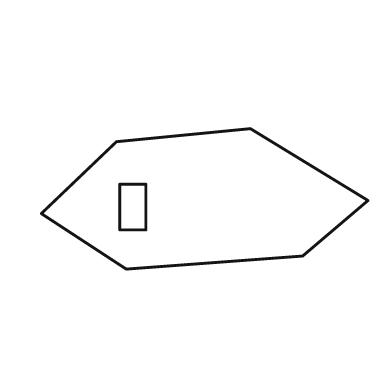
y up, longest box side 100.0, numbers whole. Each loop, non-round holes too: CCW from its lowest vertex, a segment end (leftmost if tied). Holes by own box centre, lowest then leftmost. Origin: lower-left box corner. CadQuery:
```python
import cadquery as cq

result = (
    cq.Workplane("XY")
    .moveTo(26.0, 0.0)
    .lineTo(80.0, 4.0)
    .lineTo(100.0, 21.0)
    .lineTo(64.0, 43.0)
    .lineTo(23.0, 39.0)
    .lineTo(0.0, 17.0)
    .close()
    .moveTo(24.0, 12.0)
    .lineTo(32.0, 12.0)
    .lineTo(32.0, 26.0)
    .lineTo(24.0, 26.0)
    .close()
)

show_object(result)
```